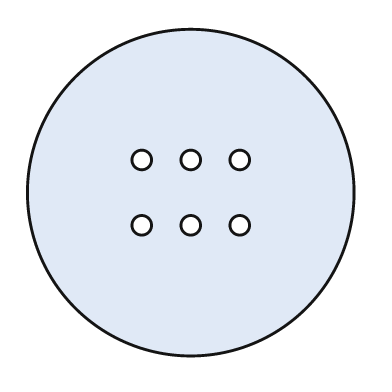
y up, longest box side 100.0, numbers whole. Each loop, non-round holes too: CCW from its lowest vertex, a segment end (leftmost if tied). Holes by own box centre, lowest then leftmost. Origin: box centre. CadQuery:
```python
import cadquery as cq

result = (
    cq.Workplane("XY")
    .moveTo(0.0, 0.0)
    .circle(50.0)
    .moveTo(-15.0, -10.0)
    .circle(3.0)
    .moveTo(0.0, -10.0)
    .circle(3.0)
    .moveTo(15.0, -10.0)
    .circle(3.0)
    .moveTo(-15.0, 10.0)
    .circle(3.0)
    .moveTo(0.0, 10.0)
    .circle(3.0)
    .moveTo(15.0, 10.0)
    .circle(3.0)
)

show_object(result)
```